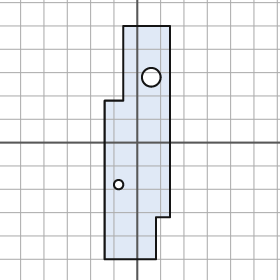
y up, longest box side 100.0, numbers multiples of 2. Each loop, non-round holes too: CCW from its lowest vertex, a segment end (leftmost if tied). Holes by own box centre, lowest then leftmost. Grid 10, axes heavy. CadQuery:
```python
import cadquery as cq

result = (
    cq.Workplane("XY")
    .moveTo(-14.0, -50.0)
    .lineTo(8.0, -50.0)
    .lineTo(8.0, -32.0)
    .lineTo(14.0, -32.0)
    .lineTo(14.0, 50.0)
    .lineTo(-6.0, 50.0)
    .lineTo(-6.0, 18.0)
    .lineTo(-14.0, 18.0)
    .close()
    .moveTo(-8.0, -18.0)
    .circle(2.0)
    .moveTo(6.0, 28.0)
    .circle(4.0)
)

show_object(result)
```